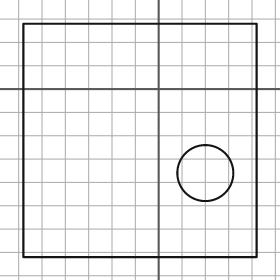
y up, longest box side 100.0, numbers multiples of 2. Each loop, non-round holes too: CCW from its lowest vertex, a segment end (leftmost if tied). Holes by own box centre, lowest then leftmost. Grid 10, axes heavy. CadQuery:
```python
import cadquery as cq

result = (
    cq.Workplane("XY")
    .moveTo(-58.0, -72.0)
    .lineTo(42.0, -72.0)
    .lineTo(42.0, 28.0)
    .lineTo(-58.0, 28.0)
    .close()
    .moveTo(20.0, -36.0)
    .circle(12.0)
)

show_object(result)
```